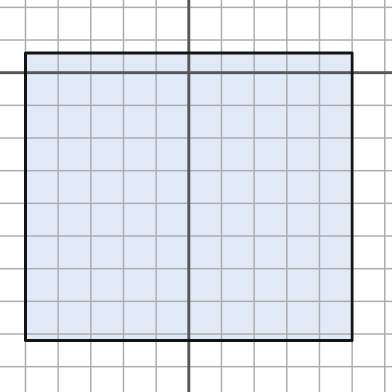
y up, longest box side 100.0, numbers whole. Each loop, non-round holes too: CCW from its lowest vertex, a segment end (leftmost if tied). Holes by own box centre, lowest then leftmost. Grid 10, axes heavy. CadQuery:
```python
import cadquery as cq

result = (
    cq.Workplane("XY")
    .moveTo(-50.0, -82.0)
    .lineTo(50.0, -82.0)
    .lineTo(50.0, 6.0)
    .lineTo(-50.0, 6.0)
    .close()
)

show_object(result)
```